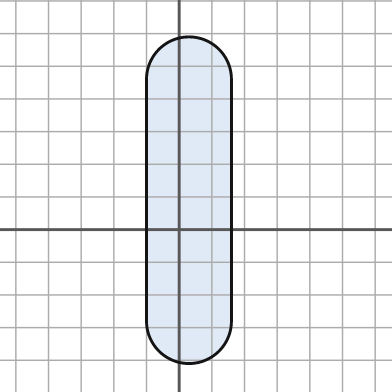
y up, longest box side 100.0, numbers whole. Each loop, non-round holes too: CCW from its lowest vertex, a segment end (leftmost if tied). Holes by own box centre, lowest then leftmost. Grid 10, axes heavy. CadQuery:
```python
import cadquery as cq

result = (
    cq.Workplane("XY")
    .moveTo(-10.0, -28.0)
    .threePointArc((3.0, -41.0), (16.0, -28.0))
    .lineTo(16.0, 46.0)
    .threePointArc((3.0, 59.0), (-10.0, 46.0))
    .close()
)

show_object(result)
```